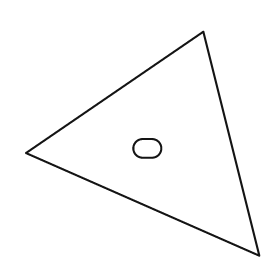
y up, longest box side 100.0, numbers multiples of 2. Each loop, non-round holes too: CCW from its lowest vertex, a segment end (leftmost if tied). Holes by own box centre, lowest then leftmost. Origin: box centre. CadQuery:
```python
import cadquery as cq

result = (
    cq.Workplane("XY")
    .moveTo(50.0, -48.0)
    .lineTo(26.0, 48.0)
    .lineTo(-50.0, -4.0)
    .close()
    .moveTo(0.0, -6.0)
    .lineTo(4.0, -6.0)
    .threePointArc((8.0, -2.0), (4.0, 2.0))
    .lineTo(0.0, 2.0)
    .threePointArc((-4.0, -2.0), (0.0, -6.0))
    .close()
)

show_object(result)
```